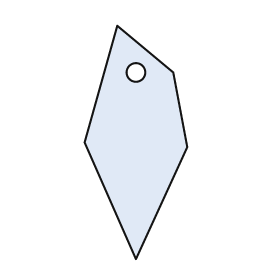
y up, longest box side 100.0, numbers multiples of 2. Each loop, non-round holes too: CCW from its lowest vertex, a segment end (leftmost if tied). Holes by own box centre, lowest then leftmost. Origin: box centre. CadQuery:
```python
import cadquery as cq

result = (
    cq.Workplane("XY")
    .moveTo(0.0, -50.0)
    .lineTo(22.0, -2.0)
    .lineTo(16.0, 30.0)
    .lineTo(-8.0, 50.0)
    .lineTo(-22.0, 0.0)
    .close()
    .moveTo(0.0, 30.0)
    .circle(4.0)
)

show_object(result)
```